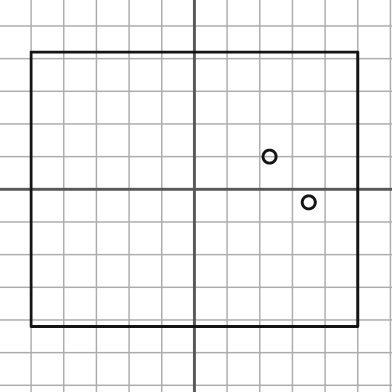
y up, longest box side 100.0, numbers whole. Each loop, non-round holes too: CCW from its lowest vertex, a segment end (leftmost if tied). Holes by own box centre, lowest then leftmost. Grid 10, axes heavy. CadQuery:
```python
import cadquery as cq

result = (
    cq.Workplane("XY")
    .moveTo(-50.0, -42.0)
    .lineTo(50.0, -42.0)
    .lineTo(50.0, 42.0)
    .lineTo(-50.0, 42.0)
    .close()
    .moveTo(35.0, -4.0)
    .circle(2.0)
    .moveTo(23.0, 10.0)
    .circle(2.0)
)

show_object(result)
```